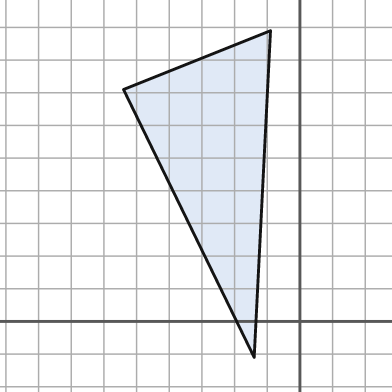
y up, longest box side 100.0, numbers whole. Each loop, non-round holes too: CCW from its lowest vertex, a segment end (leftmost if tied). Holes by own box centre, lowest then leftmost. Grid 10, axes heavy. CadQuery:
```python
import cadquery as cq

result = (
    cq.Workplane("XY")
    .moveTo(-14.0, -11.0)
    .lineTo(-9.0, 89.0)
    .lineTo(-54.0, 71.0)
    .close()
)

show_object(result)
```